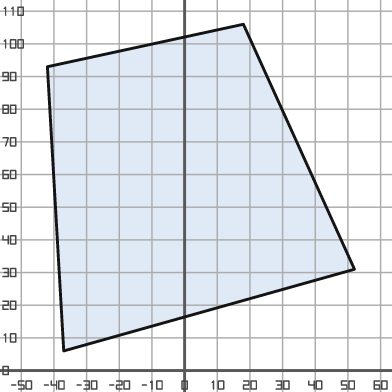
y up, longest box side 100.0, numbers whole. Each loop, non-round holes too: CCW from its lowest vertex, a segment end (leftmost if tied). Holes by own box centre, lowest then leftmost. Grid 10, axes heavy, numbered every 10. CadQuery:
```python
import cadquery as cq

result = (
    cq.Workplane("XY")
    .moveTo(-37.0, 6.0)
    .lineTo(52.0, 31.0)
    .lineTo(18.0, 106.0)
    .lineTo(-42.0, 93.0)
    .close()
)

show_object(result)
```